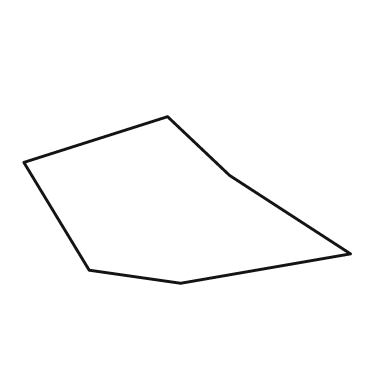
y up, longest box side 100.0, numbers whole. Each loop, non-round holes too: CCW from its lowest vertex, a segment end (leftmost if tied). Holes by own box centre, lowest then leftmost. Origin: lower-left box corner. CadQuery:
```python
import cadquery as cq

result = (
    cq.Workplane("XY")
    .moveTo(48.0, 0.0)
    .lineTo(100.0, 9.0)
    .lineTo(63.0, 33.0)
    .lineTo(44.0, 51.0)
    .lineTo(0.0, 37.0)
    .lineTo(20.0, 4.0)
    .close()
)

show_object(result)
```